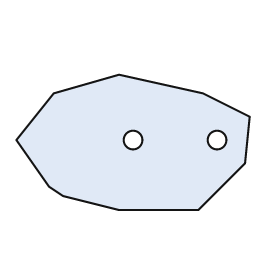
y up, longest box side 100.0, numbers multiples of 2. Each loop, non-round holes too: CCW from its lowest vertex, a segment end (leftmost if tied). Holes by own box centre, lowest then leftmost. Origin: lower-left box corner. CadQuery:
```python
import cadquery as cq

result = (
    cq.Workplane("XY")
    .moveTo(44.0, 0.0)
    .lineTo(78.0, 0.0)
    .lineTo(98.0, 20.0)
    .lineTo(100.0, 40.0)
    .lineTo(80.0, 50.0)
    .lineTo(44.0, 58.0)
    .lineTo(16.0, 50.0)
    .lineTo(0.0, 30.0)
    .lineTo(14.0, 10.0)
    .lineTo(20.0, 6.0)
    .close()
    .moveTo(50.0, 30.0)
    .circle(4.0)
    .moveTo(86.0, 30.0)
    .circle(4.0)
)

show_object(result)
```